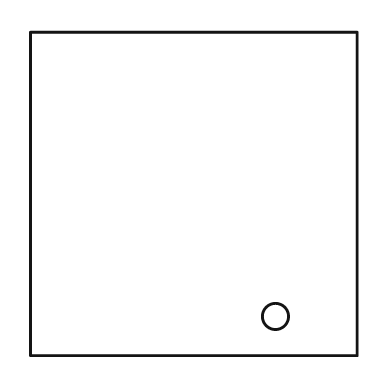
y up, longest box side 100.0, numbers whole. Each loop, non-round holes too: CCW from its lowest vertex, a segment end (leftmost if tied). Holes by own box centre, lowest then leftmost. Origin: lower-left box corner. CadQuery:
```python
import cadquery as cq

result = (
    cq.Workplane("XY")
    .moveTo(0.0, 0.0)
    .lineTo(100.0, 0.0)
    .lineTo(100.0, 99.0)
    .lineTo(0.0, 99.0)
    .close()
    .moveTo(75.0, 12.0)
    .circle(4.0)
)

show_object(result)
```